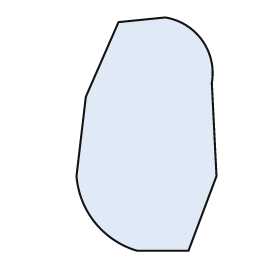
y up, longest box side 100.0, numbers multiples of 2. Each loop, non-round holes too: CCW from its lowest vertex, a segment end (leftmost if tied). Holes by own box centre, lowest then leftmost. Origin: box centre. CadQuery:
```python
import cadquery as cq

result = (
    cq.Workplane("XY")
    .moveTo(-4.0, -50.0)
    .lineTo(18.0, -50.0)
    .lineTo(30.0, -18.0)
    .lineTo(28.0, 22.0)
    .threePointArc((24.0, 40.0), (8.0, 50.0))
    .lineTo(-12.0, 48.0)
    .lineTo(-26.0, 16.0)
    .lineTo(-30.0, -18.0)
    .threePointArc((-22.0, -38.0), (-4.0, -50.0))
    .close()
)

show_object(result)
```